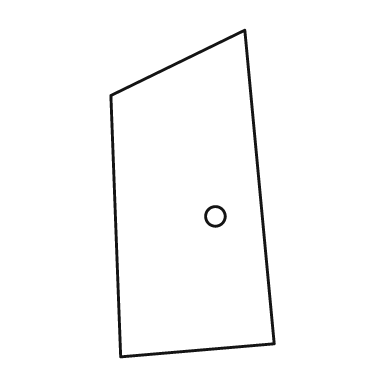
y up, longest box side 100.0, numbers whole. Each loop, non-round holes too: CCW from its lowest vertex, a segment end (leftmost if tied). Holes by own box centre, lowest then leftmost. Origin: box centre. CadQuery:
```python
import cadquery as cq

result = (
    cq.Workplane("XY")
    .moveTo(-22.0, -50.0)
    .lineTo(25.0, -46.0)
    .lineTo(16.0, 50.0)
    .lineTo(-25.0, 30.0)
    .close()
    .moveTo(7.0, -7.0)
    .circle(3.0)
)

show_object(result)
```